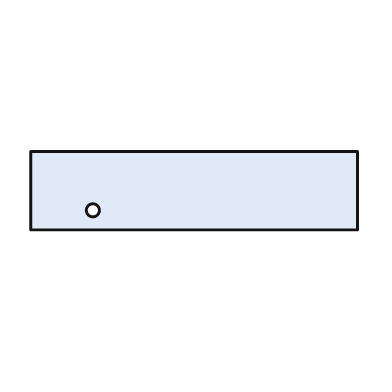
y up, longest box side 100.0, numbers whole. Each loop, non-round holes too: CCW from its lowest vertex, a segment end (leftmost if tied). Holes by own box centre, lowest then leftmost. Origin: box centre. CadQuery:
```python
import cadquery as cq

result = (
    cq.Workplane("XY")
    .moveTo(-50.0, -12.0)
    .lineTo(50.0, -12.0)
    .lineTo(50.0, 12.0)
    .lineTo(-50.0, 12.0)
    .close()
    .moveTo(-31.0, -6.0)
    .circle(2.0)
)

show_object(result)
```